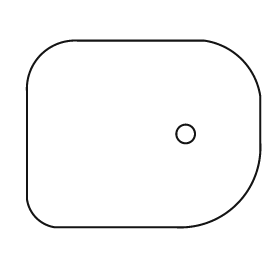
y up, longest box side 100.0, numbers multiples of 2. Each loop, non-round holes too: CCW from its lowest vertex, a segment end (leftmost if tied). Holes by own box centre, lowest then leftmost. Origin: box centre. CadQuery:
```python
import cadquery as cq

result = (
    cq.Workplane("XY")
    .moveTo(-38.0, -40.0)
    .lineTo(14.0, -40.0)
    .threePointArc((40.0, -30.0), (50.0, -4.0))
    .lineTo(50.0, 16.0)
    .threePointArc((42.0, 32.0), (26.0, 40.0))
    .lineTo(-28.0, 40.0)
    .threePointArc((-44.0, 34.0), (-50.0, 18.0))
    .lineTo(-50.0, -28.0)
    .threePointArc((-46.0, -36.0), (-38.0, -40.0))
    .close()
    .moveTo(18.0, 0.0)
    .circle(4.0)
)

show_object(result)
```